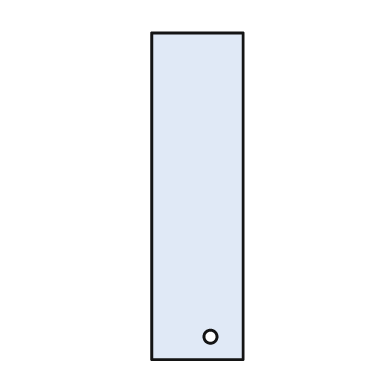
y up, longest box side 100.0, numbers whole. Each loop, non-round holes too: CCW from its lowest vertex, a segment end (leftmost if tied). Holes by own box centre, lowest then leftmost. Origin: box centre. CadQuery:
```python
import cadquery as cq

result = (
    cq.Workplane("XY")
    .moveTo(-14.0, -50.0)
    .lineTo(14.0, -50.0)
    .lineTo(14.0, 50.0)
    .lineTo(-14.0, 50.0)
    .close()
    .moveTo(4.0, -43.0)
    .circle(2.0)
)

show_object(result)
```